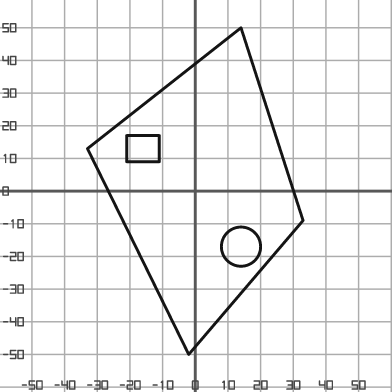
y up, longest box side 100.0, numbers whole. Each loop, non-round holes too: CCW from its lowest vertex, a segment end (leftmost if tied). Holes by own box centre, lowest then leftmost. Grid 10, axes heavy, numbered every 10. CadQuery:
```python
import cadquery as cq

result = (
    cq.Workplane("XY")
    .moveTo(-2.0, -50.0)
    .lineTo(33.0, -9.0)
    .lineTo(14.0, 50.0)
    .lineTo(-33.0, 13.0)
    .close()
    .moveTo(14.0, -17.0)
    .circle(6.0)
    .moveTo(-21.0, 9.0)
    .lineTo(-11.0, 9.0)
    .lineTo(-11.0, 17.0)
    .lineTo(-21.0, 17.0)
    .close()
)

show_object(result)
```